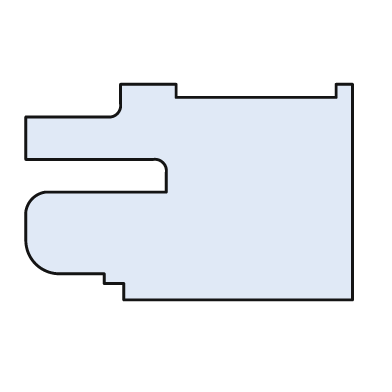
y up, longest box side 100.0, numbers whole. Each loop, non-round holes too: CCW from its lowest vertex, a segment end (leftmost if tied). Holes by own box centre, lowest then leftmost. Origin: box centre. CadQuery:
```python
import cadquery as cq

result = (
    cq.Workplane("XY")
    .moveTo(-20.0, -33.0)
    .lineTo(50.0, -33.0)
    .lineTo(50.0, 33.0)
    .lineTo(45.0, 33.0)
    .lineTo(45.0, 29.0)
    .lineTo(-4.0, 29.0)
    .lineTo(-4.0, 33.0)
    .lineTo(-21.0, 33.0)
    .lineTo(-21.0, 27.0)
    .threePointArc((-22.0, 24.0), (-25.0, 23.0))
    .lineTo(-50.0, 23.0)
    .lineTo(-50.0, 10.0)
    .lineTo(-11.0, 10.0)
    .threePointArc((-8.0, 9.0), (-7.0, 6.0))
    .lineTo(-7.0, 0.0)
    .lineTo(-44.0, 0.0)
    .threePointArc((-48.0, -2.0), (-50.0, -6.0))
    .lineTo(-50.0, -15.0)
    .threePointArc((-47.0, -22.0), (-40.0, -25.0))
    .lineTo(-26.0, -25.0)
    .lineTo(-26.0, -28.0)
    .lineTo(-20.0, -28.0)
    .close()
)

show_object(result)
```